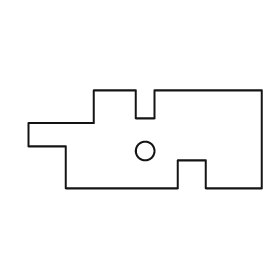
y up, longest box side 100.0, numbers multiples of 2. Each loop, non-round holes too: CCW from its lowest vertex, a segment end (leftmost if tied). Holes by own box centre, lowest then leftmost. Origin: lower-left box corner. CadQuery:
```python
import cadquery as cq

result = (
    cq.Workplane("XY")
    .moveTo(16.0, 0.0)
    .lineTo(64.0, 0.0)
    .lineTo(64.0, 12.0)
    .lineTo(76.0, 12.0)
    .lineTo(76.0, 0.0)
    .lineTo(100.0, 0.0)
    .lineTo(100.0, 42.0)
    .lineTo(54.0, 42.0)
    .lineTo(54.0, 30.0)
    .lineTo(46.0, 30.0)
    .lineTo(46.0, 42.0)
    .lineTo(28.0, 42.0)
    .lineTo(28.0, 28.0)
    .lineTo(0.0, 28.0)
    .lineTo(0.0, 18.0)
    .lineTo(16.0, 18.0)
    .close()
    .moveTo(50.0, 16.0)
    .circle(4.0)
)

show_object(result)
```